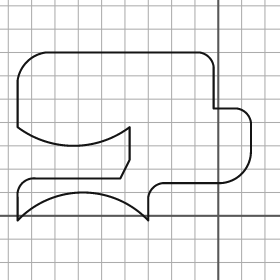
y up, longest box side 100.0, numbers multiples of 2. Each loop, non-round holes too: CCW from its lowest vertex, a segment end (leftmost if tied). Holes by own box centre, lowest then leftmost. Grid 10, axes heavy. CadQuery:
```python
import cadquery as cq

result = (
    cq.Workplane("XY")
    .moveTo(-86.0, -2.0)
    .threePointArc((-58.0, 10.0), (-30.0, -2.0))
    .lineTo(-30.0, 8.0)
    .threePointArc((-28.0, 12.0), (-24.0, 14.0))
    .lineTo(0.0, 14.0)
    .threePointArc((10.0, 18.0), (14.0, 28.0))
    .lineTo(14.0, 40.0)
    .threePointArc((12.0, 44.0), (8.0, 46.0))
    .lineTo(-2.0, 46.0)
    .lineTo(-2.0, 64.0)
    .threePointArc((-4.0, 68.0), (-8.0, 70.0))
    .lineTo(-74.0, 70.0)
    .threePointArc((-82.0, 66.0), (-86.0, 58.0))
    .lineTo(-86.0, 38.0)
    .threePointArc((-62.0, 30.0), (-38.0, 38.0))
    .lineTo(-38.0, 24.0)
    .lineTo(-42.0, 16.0)
    .lineTo(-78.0, 16.0)
    .threePointArc((-84.0, 14.0), (-86.0, 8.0))
    .close()
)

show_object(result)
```